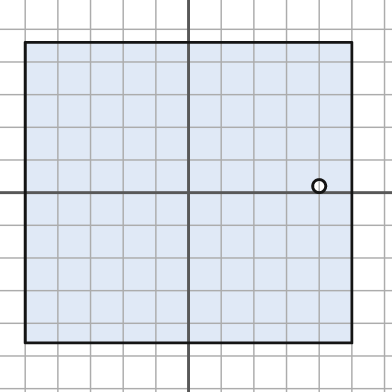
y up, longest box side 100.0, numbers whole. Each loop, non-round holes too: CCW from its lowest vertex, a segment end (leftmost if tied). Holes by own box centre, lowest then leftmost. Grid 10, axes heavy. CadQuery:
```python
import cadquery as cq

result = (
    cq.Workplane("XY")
    .moveTo(-50.0, -46.0)
    .lineTo(50.0, -46.0)
    .lineTo(50.0, 46.0)
    .lineTo(-50.0, 46.0)
    .close()
    .moveTo(40.0, 2.0)
    .circle(2.0)
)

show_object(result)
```